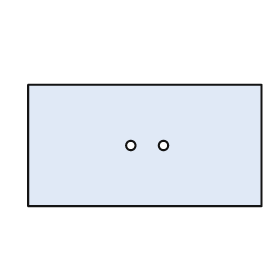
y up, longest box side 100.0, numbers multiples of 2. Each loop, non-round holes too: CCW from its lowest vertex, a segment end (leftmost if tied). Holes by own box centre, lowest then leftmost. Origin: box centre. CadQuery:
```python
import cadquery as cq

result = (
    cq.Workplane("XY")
    .moveTo(-50.0, -26.0)
    .lineTo(50.0, -26.0)
    .lineTo(50.0, 26.0)
    .lineTo(-50.0, 26.0)
    .close()
    .moveTo(-6.0, 0.0)
    .circle(2.0)
    .moveTo(8.0, 0.0)
    .circle(2.0)
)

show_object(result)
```